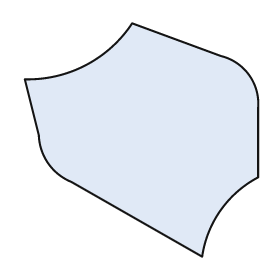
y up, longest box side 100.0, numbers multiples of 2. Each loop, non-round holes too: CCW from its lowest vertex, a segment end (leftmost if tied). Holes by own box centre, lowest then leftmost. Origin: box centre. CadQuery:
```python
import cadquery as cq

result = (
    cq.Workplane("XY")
    .moveTo(26.0, -50.0)
    .threePointArc((34.0, -30.0), (50.0, -16.0))
    .lineTo(50.0, 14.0)
    .threePointArc((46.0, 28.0), (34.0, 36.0))
    .lineTo(-4.0, 50.0)
    .threePointArc((-24.0, 32.0), (-50.0, 26.0))
    .lineTo(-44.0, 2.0)
    .threePointArc((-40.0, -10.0), (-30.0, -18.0))
    .close()
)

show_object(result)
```